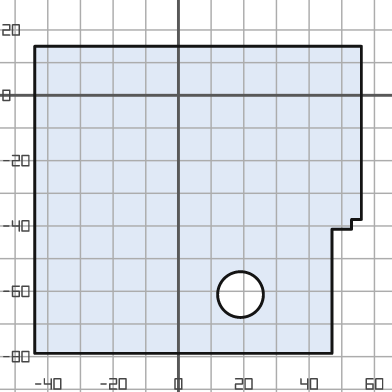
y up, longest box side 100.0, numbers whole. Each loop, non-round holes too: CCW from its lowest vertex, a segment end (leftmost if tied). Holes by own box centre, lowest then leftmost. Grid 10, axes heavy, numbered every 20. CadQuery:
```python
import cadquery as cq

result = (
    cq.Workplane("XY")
    .moveTo(-44.0, -79.0)
    .lineTo(47.0, -79.0)
    .lineTo(47.0, -41.0)
    .lineTo(53.0, -41.0)
    .lineTo(53.0, -38.0)
    .lineTo(56.0, -38.0)
    .lineTo(56.0, 15.0)
    .lineTo(-44.0, 15.0)
    .close()
    .moveTo(19.0, -61.0)
    .circle(7.0)
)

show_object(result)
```